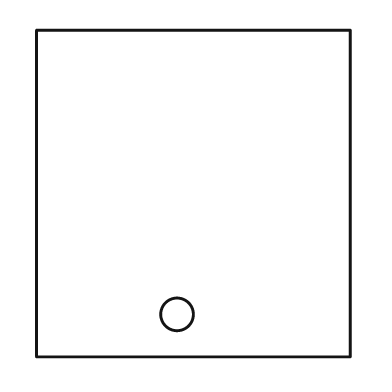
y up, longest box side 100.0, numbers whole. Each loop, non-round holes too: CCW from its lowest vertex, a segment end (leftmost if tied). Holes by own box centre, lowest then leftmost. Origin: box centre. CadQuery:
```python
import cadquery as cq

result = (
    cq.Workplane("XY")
    .moveTo(-48.0, -50.0)
    .lineTo(48.0, -50.0)
    .lineTo(48.0, 50.0)
    .lineTo(-48.0, 50.0)
    .close()
    .moveTo(-5.0, -37.0)
    .circle(5.0)
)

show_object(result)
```